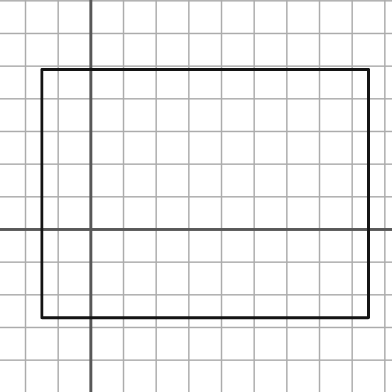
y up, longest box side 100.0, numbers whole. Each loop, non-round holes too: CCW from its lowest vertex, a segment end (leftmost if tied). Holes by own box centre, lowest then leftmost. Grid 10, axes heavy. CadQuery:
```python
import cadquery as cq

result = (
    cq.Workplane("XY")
    .moveTo(-15.0, -27.0)
    .lineTo(85.0, -27.0)
    .lineTo(85.0, 49.0)
    .lineTo(-15.0, 49.0)
    .close()
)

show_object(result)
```